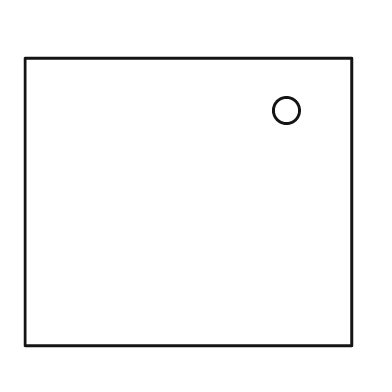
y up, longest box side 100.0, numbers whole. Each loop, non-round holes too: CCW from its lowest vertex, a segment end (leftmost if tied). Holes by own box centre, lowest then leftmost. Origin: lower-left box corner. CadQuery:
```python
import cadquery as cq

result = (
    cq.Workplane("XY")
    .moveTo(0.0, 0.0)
    .lineTo(100.0, 0.0)
    .lineTo(100.0, 88.0)
    .lineTo(0.0, 88.0)
    .close()
    .moveTo(80.0, 72.0)
    .circle(4.0)
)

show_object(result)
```